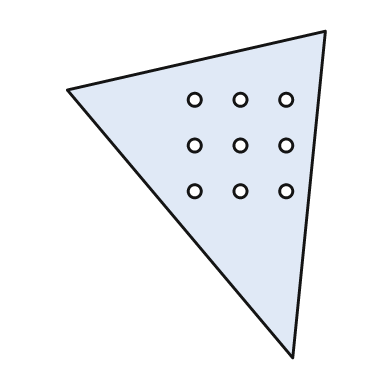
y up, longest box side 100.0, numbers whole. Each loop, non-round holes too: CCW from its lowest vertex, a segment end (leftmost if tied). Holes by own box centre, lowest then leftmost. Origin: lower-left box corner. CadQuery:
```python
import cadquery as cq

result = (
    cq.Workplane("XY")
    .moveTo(69.0, 0.0)
    .lineTo(79.0, 100.0)
    .lineTo(0.0, 82.0)
    .close()
    .moveTo(39.0, 51.0)
    .circle(2.0)
    .moveTo(53.0, 51.0)
    .circle(2.0)
    .moveTo(67.0, 51.0)
    .circle(2.0)
    .moveTo(39.0, 65.0)
    .circle(2.0)
    .moveTo(53.0, 65.0)
    .circle(2.0)
    .moveTo(67.0, 65.0)
    .circle(2.0)
    .moveTo(39.0, 79.0)
    .circle(2.0)
    .moveTo(53.0, 79.0)
    .circle(2.0)
    .moveTo(67.0, 79.0)
    .circle(2.0)
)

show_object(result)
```